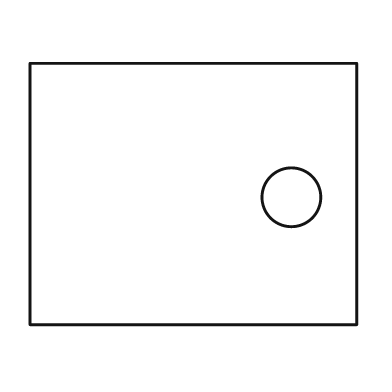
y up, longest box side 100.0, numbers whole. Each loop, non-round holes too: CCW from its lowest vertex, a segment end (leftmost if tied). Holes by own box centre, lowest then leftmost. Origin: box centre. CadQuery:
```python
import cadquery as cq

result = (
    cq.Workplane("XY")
    .moveTo(-50.0, -40.0)
    .lineTo(50.0, -40.0)
    .lineTo(50.0, 40.0)
    .lineTo(-50.0, 40.0)
    .close()
    .moveTo(30.0, -1.0)
    .circle(9.0)
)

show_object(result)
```